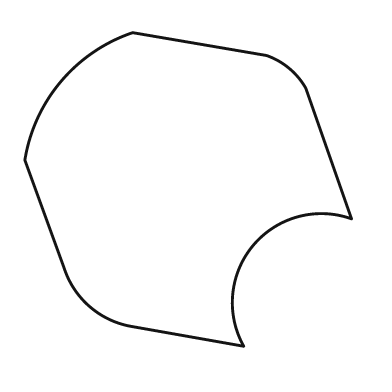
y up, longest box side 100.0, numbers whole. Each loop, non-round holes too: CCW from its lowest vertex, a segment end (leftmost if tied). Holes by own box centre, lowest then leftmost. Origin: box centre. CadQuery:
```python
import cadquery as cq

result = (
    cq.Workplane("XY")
    .moveTo(17.0, -48.0)
    .threePointArc((20.0, -17.0), (50.0, -9.0))
    .lineTo(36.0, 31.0)
    .threePointArc((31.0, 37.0), (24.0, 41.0))
    .lineTo(-17.0, 48.0)
    .threePointArc((-39.0, 33.0), (-50.0, 9.0))
    .lineTo(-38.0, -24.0)
    .threePointArc((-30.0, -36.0), (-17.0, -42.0))
    .close()
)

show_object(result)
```